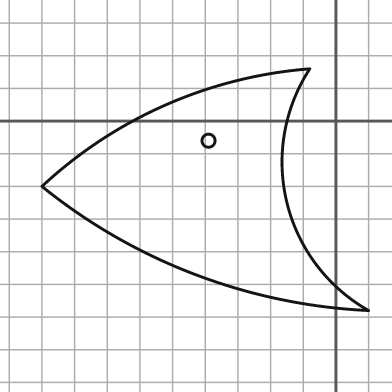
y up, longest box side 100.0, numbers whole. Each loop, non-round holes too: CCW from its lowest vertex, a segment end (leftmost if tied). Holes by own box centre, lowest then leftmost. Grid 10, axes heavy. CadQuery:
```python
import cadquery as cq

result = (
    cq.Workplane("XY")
    .moveTo(10.0, -58.0)
    .threePointArc((-15.0, -25.0), (-8.0, 16.0))
    .threePointArc((-52.0, 5.0), (-90.0, -20.0))
    .threePointArc((-43.0, -47.0), (10.0, -58.0))
    .close()
    .moveTo(-39.0, -6.0)
    .circle(2.0)
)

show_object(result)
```